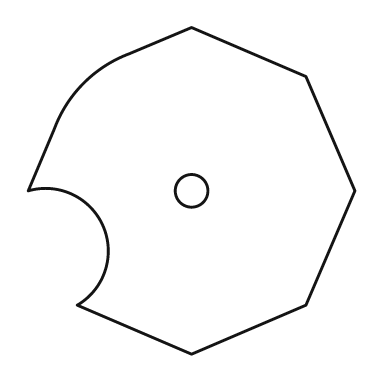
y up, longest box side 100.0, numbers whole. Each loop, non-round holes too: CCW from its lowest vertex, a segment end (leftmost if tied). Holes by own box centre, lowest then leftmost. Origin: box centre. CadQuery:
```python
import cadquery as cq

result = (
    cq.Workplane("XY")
    .moveTo(0.0, -50.0)
    .lineTo(35.0, -35.0)
    .lineTo(50.0, 0.0)
    .lineTo(35.0, 35.0)
    .lineTo(0.0, 50.0)
    .lineTo(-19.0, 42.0)
    .threePointArc((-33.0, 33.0), (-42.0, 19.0))
    .lineTo(-50.0, 0.0)
    .threePointArc((-27.0, -11.0), (-35.0, -35.0))
    .close()
    .moveTo(0.0, 0.0)
    .circle(5.0)
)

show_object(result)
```